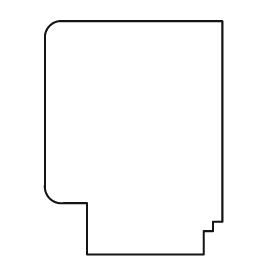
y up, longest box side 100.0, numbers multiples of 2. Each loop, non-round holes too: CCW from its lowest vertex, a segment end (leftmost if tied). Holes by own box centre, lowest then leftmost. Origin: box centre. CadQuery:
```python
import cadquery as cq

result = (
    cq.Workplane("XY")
    .moveTo(-20.0, -50.0)
    .lineTo(30.0, -50.0)
    .lineTo(30.0, -40.0)
    .lineTo(34.0, -40.0)
    .lineTo(34.0, -36.0)
    .lineTo(38.0, -36.0)
    .lineTo(38.0, 50.0)
    .lineTo(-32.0, 50.0)
    .threePointArc((-36.0, 48.0), (-38.0, 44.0))
    .lineTo(-38.0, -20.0)
    .threePointArc((-36.0, -26.0), (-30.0, -28.0))
    .lineTo(-20.0, -28.0)
    .close()
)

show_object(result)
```